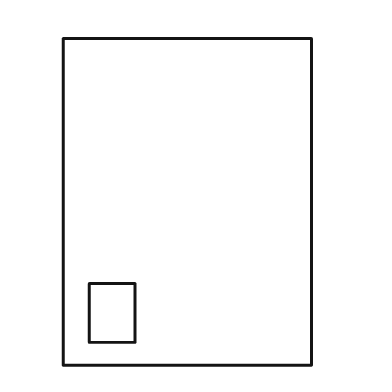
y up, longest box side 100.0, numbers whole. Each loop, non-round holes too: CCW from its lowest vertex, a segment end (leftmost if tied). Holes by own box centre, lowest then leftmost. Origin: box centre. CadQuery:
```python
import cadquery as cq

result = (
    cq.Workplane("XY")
    .moveTo(-38.0, -50.0)
    .lineTo(38.0, -50.0)
    .lineTo(38.0, 50.0)
    .lineTo(-38.0, 50.0)
    .close()
    .moveTo(-30.0, -43.0)
    .lineTo(-16.0, -43.0)
    .lineTo(-16.0, -25.0)
    .lineTo(-30.0, -25.0)
    .close()
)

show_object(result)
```